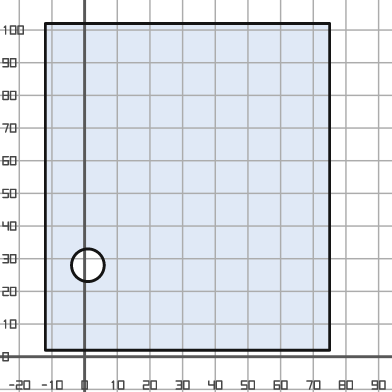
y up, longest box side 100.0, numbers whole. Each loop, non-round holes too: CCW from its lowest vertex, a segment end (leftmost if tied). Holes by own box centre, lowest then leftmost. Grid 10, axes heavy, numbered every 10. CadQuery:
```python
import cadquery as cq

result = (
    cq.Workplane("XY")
    .moveTo(-12.0, 2.0)
    .lineTo(75.0, 2.0)
    .lineTo(75.0, 102.0)
    .lineTo(-12.0, 102.0)
    .close()
    .moveTo(1.0, 28.0)
    .circle(5.0)
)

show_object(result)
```